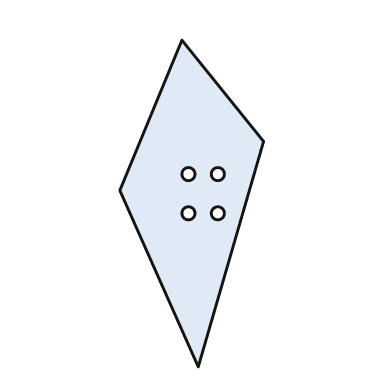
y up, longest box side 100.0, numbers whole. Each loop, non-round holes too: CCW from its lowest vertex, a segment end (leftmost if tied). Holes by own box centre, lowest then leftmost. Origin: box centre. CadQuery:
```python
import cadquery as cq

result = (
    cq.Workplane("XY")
    .moveTo(2.0, -50.0)
    .lineTo(22.0, 19.0)
    .lineTo(-3.0, 50.0)
    .lineTo(-22.0, 4.0)
    .close()
    .moveTo(-1.0, -3.0)
    .circle(2.0)
    .moveTo(8.0, -3.0)
    .circle(2.0)
    .moveTo(-1.0, 9.0)
    .circle(2.0)
    .moveTo(8.0, 9.0)
    .circle(2.0)
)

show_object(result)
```